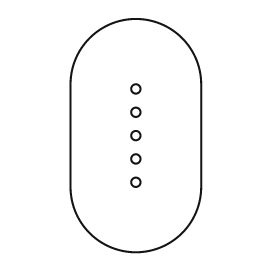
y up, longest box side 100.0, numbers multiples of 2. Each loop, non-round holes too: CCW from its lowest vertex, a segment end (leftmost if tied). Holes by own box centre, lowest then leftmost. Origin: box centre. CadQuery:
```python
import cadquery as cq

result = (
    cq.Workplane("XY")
    .moveTo(-28.0, -22.0)
    .threePointArc((0.0, -50.0), (28.0, -22.0))
    .lineTo(28.0, 22.0)
    .threePointArc((0.0, 50.0), (-28.0, 22.0))
    .close()
    .moveTo(0.0, -20.0)
    .circle(2.0)
    .moveTo(0.0, -10.0)
    .circle(2.0)
    .moveTo(0.0, 0.0)
    .circle(2.0)
    .moveTo(0.0, 10.0)
    .circle(2.0)
    .moveTo(0.0, 20.0)
    .circle(2.0)
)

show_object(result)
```